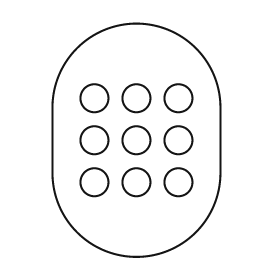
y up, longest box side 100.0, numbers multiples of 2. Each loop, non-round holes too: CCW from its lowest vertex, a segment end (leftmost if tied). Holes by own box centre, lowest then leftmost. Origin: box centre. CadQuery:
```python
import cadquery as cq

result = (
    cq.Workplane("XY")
    .moveTo(-36.0, -14.0)
    .threePointArc((0.0, -50.0), (36.0, -14.0))
    .lineTo(36.0, 14.0)
    .threePointArc((0.0, 50.0), (-36.0, 14.0))
    .close()
    .moveTo(-18.0, -18.0)
    .circle(6.0)
    .moveTo(0.0, -18.0)
    .circle(6.0)
    .moveTo(18.0, -18.0)
    .circle(6.0)
    .moveTo(-18.0, 0.0)
    .circle(6.0)
    .moveTo(0.0, 0.0)
    .circle(6.0)
    .moveTo(18.0, 0.0)
    .circle(6.0)
    .moveTo(-18.0, 18.0)
    .circle(6.0)
    .moveTo(0.0, 18.0)
    .circle(6.0)
    .moveTo(18.0, 18.0)
    .circle(6.0)
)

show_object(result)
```